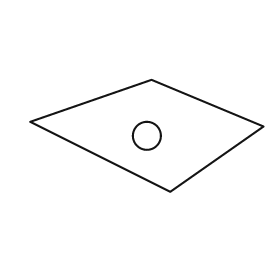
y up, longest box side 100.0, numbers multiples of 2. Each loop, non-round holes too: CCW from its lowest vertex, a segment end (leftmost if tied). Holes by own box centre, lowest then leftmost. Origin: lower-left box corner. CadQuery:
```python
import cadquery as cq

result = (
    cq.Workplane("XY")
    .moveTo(60.0, 0.0)
    .lineTo(100.0, 28.0)
    .lineTo(52.0, 48.0)
    .lineTo(0.0, 30.0)
    .close()
    .moveTo(50.0, 24.0)
    .circle(6.0)
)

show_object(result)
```